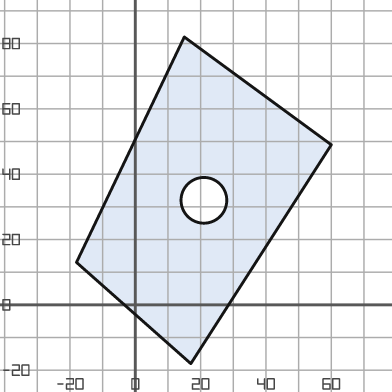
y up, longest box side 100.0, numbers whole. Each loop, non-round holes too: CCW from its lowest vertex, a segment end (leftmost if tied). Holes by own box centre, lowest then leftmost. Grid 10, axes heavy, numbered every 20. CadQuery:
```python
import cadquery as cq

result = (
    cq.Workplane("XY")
    .moveTo(17.0, -18.0)
    .lineTo(60.0, 49.0)
    .lineTo(15.0, 82.0)
    .lineTo(-18.0, 13.0)
    .close()
    .moveTo(21.0, 32.0)
    .circle(7.0)
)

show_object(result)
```